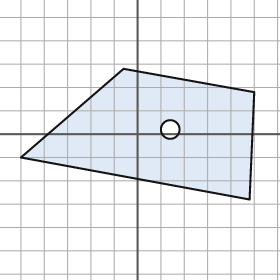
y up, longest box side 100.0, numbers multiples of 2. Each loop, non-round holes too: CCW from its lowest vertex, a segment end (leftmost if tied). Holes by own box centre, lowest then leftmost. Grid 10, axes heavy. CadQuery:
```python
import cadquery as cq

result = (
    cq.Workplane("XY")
    .moveTo(48.0, -28.0)
    .lineTo(50.0, 18.0)
    .lineTo(-6.0, 28.0)
    .lineTo(-50.0, -10.0)
    .close()
    .moveTo(14.0, 2.0)
    .circle(4.0)
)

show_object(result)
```